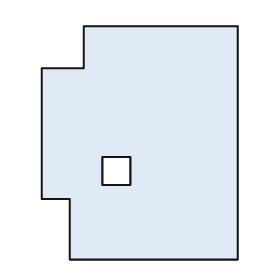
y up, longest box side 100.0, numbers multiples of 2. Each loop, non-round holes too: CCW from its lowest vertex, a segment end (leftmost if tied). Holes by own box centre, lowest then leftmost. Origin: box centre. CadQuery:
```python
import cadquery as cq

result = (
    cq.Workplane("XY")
    .moveTo(-30.0, -50.0)
    .lineTo(42.0, -50.0)
    .lineTo(42.0, 50.0)
    .lineTo(-24.0, 50.0)
    .lineTo(-24.0, 32.0)
    .lineTo(-42.0, 32.0)
    .lineTo(-42.0, -24.0)
    .lineTo(-30.0, -24.0)
    .close()
    .moveTo(-16.0, -18.0)
    .lineTo(-4.0, -18.0)
    .lineTo(-4.0, -6.0)
    .lineTo(-16.0, -6.0)
    .close()
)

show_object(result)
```